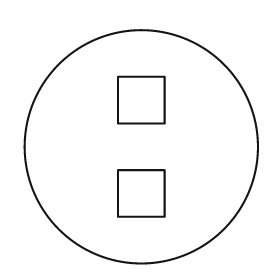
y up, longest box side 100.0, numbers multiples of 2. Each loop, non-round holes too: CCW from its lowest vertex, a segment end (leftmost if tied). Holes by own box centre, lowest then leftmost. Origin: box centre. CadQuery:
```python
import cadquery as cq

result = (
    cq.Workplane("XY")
    .moveTo(0.0, 0.0)
    .circle(50.0)
    .moveTo(-10.0, -30.0)
    .lineTo(10.0, -30.0)
    .lineTo(10.0, -10.0)
    .lineTo(-10.0, -10.0)
    .close()
    .moveTo(-10.0, 10.0)
    .lineTo(10.0, 10.0)
    .lineTo(10.0, 30.0)
    .lineTo(-10.0, 30.0)
    .close()
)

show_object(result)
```